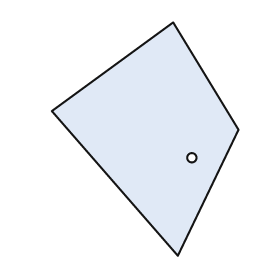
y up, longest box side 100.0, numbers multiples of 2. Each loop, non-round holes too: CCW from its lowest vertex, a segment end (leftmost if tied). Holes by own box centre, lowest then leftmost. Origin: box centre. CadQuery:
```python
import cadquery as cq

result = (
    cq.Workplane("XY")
    .moveTo(14.0, -50.0)
    .lineTo(40.0, 4.0)
    .lineTo(12.0, 50.0)
    .lineTo(-40.0, 12.0)
    .close()
    .moveTo(20.0, -8.0)
    .circle(2.0)
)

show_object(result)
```